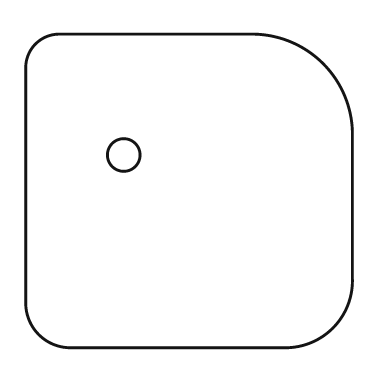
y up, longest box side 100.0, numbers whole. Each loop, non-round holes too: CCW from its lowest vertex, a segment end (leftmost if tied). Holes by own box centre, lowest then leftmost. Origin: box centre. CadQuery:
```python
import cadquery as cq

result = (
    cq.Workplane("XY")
    .moveTo(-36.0, -48.0)
    .lineTo(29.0, -48.0)
    .threePointArc((44.0, -42.0), (50.0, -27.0))
    .lineTo(50.0, 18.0)
    .threePointArc((41.0, 39.0), (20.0, 48.0))
    .lineTo(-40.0, 48.0)
    .threePointArc((-47.0, 45.0), (-50.0, 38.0))
    .lineTo(-50.0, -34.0)
    .threePointArc((-46.0, -44.0), (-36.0, -48.0))
    .close()
    .moveTo(-20.0, 11.0)
    .circle(5.0)
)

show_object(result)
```